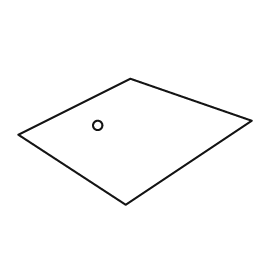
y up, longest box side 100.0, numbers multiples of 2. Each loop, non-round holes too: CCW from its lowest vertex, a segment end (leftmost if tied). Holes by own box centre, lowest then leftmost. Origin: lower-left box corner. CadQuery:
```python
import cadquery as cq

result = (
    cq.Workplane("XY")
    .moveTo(46.0, 0.0)
    .lineTo(100.0, 36.0)
    .lineTo(48.0, 54.0)
    .lineTo(0.0, 30.0)
    .close()
    .moveTo(34.0, 34.0)
    .circle(2.0)
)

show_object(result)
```